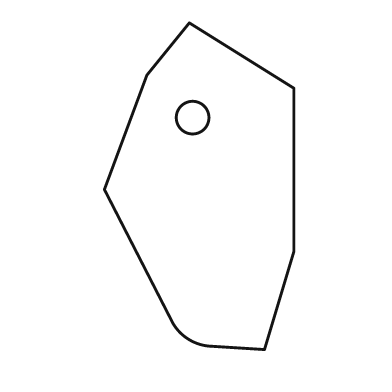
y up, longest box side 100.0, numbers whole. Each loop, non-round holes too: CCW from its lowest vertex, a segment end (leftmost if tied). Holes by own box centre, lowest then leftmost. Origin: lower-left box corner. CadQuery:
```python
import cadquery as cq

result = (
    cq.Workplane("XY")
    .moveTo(49.0, 0.0)
    .lineTo(58.0, 30.0)
    .lineTo(58.0, 80.0)
    .lineTo(26.0, 100.0)
    .lineTo(13.0, 84.0)
    .lineTo(0.0, 49.0)
    .lineTo(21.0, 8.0)
    .threePointArc((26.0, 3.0), (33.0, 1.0))
    .close()
    .moveTo(27.0, 71.0)
    .circle(5.0)
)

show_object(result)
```